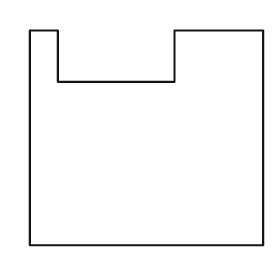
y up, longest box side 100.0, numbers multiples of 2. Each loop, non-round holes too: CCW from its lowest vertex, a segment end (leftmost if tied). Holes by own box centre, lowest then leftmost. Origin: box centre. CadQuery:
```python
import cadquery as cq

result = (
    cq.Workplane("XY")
    .moveTo(-50.0, -46.0)
    .lineTo(50.0, -46.0)
    .lineTo(50.0, 46.0)
    .lineTo(12.0, 46.0)
    .lineTo(12.0, 24.0)
    .lineTo(-38.0, 24.0)
    .lineTo(-38.0, 46.0)
    .lineTo(-50.0, 46.0)
    .close()
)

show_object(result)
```